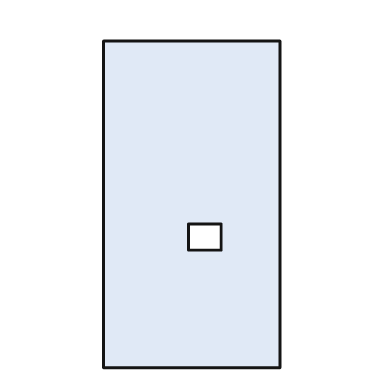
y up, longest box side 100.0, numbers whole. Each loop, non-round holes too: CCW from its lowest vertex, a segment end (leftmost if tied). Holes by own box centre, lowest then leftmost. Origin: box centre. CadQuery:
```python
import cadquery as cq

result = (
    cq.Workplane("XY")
    .moveTo(-27.0, -50.0)
    .lineTo(27.0, -50.0)
    .lineTo(27.0, 50.0)
    .lineTo(-27.0, 50.0)
    .close()
    .moveTo(-1.0, -14.0)
    .lineTo(9.0, -14.0)
    .lineTo(9.0, -6.0)
    .lineTo(-1.0, -6.0)
    .close()
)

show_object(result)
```